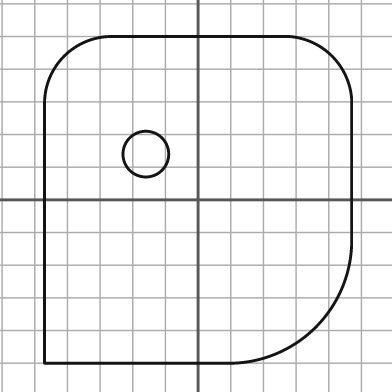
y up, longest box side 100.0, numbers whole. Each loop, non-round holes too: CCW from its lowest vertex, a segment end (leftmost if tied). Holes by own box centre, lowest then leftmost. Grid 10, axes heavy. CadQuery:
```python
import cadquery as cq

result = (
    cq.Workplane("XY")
    .moveTo(-47.0, -50.0)
    .lineTo(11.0, -50.0)
    .threePointArc((36.0, -39.0), (47.0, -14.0))
    .lineTo(47.0, 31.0)
    .threePointArc((41.0, 44.0), (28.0, 50.0))
    .lineTo(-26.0, 50.0)
    .threePointArc((-41.0, 44.0), (-47.0, 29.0))
    .close()
    .moveTo(-16.0, 14.0)
    .circle(7.0)
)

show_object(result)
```